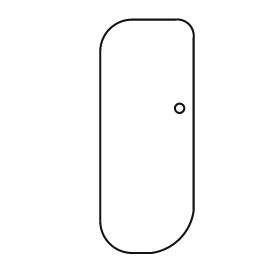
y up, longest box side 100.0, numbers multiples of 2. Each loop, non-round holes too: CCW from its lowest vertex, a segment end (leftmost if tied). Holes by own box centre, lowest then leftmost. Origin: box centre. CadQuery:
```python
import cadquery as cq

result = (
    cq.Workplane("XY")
    .moveTo(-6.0, -50.0)
    .lineTo(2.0, -50.0)
    .threePointArc((14.0, -44.0), (20.0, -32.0))
    .lineTo(20.0, 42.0)
    .threePointArc((18.0, 48.0), (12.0, 50.0))
    .lineTo(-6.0, 50.0)
    .threePointArc((-16.0, 46.0), (-20.0, 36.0))
    .lineTo(-20.0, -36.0)
    .threePointArc((-16.0, -46.0), (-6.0, -50.0))
    .close()
    .moveTo(14.0, 12.0)
    .circle(2.0)
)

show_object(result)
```